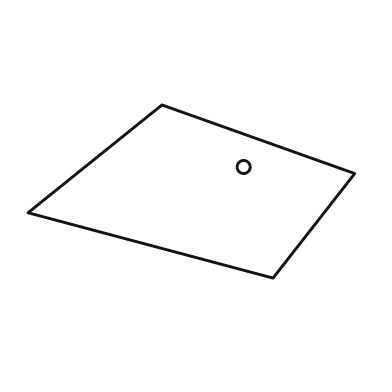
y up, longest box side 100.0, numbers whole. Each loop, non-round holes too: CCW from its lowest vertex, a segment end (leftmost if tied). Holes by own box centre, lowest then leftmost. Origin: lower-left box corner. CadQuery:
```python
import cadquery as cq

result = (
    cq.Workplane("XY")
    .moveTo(75.0, 0.0)
    .lineTo(100.0, 32.0)
    .lineTo(41.0, 53.0)
    .lineTo(0.0, 20.0)
    .close()
    .moveTo(66.0, 34.0)
    .circle(2.0)
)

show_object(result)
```